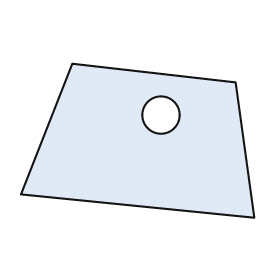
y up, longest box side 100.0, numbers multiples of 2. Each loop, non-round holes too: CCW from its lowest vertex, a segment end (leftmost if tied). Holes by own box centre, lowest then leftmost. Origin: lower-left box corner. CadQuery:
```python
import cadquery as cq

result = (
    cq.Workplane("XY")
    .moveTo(100.0, 0.0)
    .lineTo(92.0, 58.0)
    .lineTo(22.0, 66.0)
    .lineTo(0.0, 10.0)
    .close()
    .moveTo(60.0, 44.0)
    .circle(8.0)
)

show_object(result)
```